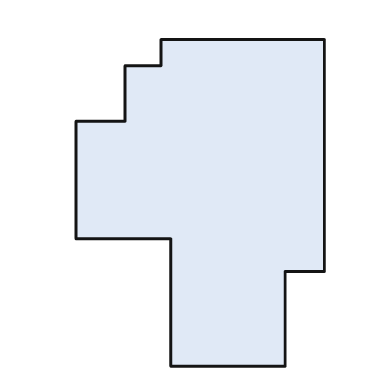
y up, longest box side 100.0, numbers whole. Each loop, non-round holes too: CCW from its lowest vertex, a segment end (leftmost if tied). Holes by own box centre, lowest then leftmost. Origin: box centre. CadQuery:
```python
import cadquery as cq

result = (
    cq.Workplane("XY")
    .moveTo(-9.0, -50.0)
    .lineTo(26.0, -50.0)
    .lineTo(26.0, -21.0)
    .lineTo(38.0, -21.0)
    .lineTo(38.0, 50.0)
    .lineTo(-12.0, 50.0)
    .lineTo(-12.0, 42.0)
    .lineTo(-23.0, 42.0)
    .lineTo(-23.0, 25.0)
    .lineTo(-38.0, 25.0)
    .lineTo(-38.0, -11.0)
    .lineTo(-9.0, -11.0)
    .close()
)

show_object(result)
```